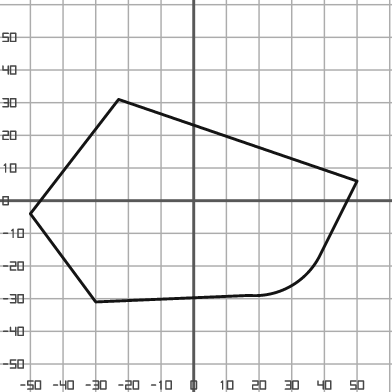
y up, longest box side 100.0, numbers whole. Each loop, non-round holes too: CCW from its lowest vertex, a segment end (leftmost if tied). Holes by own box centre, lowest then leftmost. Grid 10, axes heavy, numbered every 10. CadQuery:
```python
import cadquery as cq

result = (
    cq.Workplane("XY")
    .moveTo(-30.0, -31.0)
    .lineTo(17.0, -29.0)
    .threePointArc((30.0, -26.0), (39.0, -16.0))
    .lineTo(50.0, 6.0)
    .lineTo(-23.0, 31.0)
    .lineTo(-50.0, -4.0)
    .close()
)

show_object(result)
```